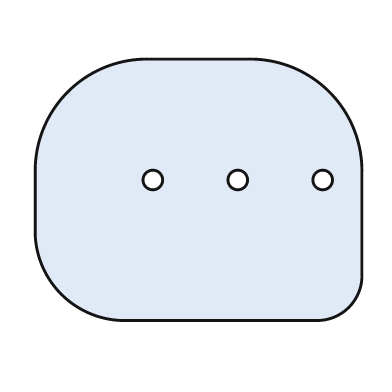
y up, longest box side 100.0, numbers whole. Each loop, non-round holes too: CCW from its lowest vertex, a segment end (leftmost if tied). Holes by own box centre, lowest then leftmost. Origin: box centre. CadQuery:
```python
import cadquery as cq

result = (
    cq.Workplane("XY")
    .moveTo(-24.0, -40.0)
    .lineTo(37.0, -40.0)
    .threePointArc((46.0, -36.0), (50.0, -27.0))
    .lineTo(50.0, 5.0)
    .threePointArc((40.0, 30.0), (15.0, 40.0))
    .lineTo(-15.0, 40.0)
    .threePointArc((-40.0, 30.0), (-50.0, 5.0))
    .lineTo(-50.0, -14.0)
    .threePointArc((-42.0, -32.0), (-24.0, -40.0))
    .close()
    .moveTo(-14.0, 3.0)
    .circle(3.0)
    .moveTo(12.0, 3.0)
    .circle(3.0)
    .moveTo(38.0, 3.0)
    .circle(3.0)
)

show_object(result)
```